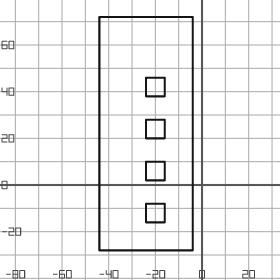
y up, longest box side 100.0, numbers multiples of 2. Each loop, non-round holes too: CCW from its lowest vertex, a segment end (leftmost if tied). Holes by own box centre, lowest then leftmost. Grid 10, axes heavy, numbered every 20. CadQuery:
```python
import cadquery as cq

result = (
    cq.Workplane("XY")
    .moveTo(-44.0, -28.0)
    .lineTo(-4.0, -28.0)
    .lineTo(-4.0, 72.0)
    .lineTo(-44.0, 72.0)
    .close()
    .moveTo(-24.0, -16.0)
    .lineTo(-16.0, -16.0)
    .lineTo(-16.0, -8.0)
    .lineTo(-24.0, -8.0)
    .close()
    .moveTo(-24.0, 2.0)
    .lineTo(-16.0, 2.0)
    .lineTo(-16.0, 10.0)
    .lineTo(-24.0, 10.0)
    .close()
    .moveTo(-24.0, 20.0)
    .lineTo(-16.0, 20.0)
    .lineTo(-16.0, 28.0)
    .lineTo(-24.0, 28.0)
    .close()
    .moveTo(-24.0, 38.0)
    .lineTo(-16.0, 38.0)
    .lineTo(-16.0, 46.0)
    .lineTo(-24.0, 46.0)
    .close()
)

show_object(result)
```